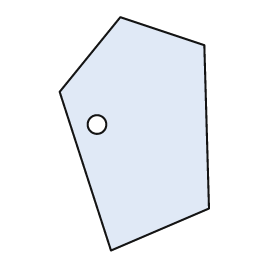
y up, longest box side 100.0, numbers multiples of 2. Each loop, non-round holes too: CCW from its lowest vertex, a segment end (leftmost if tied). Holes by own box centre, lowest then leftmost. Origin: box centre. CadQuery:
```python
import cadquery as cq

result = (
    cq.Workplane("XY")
    .moveTo(-10.0, -50.0)
    .lineTo(32.0, -32.0)
    .lineTo(30.0, 38.0)
    .lineTo(-6.0, 50.0)
    .lineTo(-32.0, 18.0)
    .close()
    .moveTo(-16.0, 4.0)
    .circle(4.0)
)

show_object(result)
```